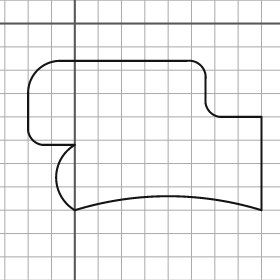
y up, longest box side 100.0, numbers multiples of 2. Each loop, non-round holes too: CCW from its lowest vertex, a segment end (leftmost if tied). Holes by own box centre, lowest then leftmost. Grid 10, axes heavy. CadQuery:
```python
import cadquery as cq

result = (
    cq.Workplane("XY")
    .moveTo(0.0, -80.0)
    .threePointArc((40.0, -74.0), (80.0, -80.0))
    .lineTo(80.0, -40.0)
    .lineTo(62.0, -40.0)
    .threePointArc((58.0, -38.0), (56.0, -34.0))
    .lineTo(56.0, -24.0)
    .threePointArc((54.0, -18.0), (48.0, -16.0))
    .lineTo(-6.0, -16.0)
    .threePointArc((-16.0, -20.0), (-20.0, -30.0))
    .lineTo(-20.0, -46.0)
    .threePointArc((-18.0, -50.0), (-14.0, -52.0))
    .lineTo(0.0, -52.0)
    .threePointArc((-8.0, -66.0), (0.0, -80.0))
    .close()
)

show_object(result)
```